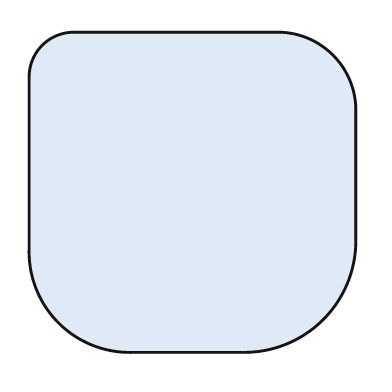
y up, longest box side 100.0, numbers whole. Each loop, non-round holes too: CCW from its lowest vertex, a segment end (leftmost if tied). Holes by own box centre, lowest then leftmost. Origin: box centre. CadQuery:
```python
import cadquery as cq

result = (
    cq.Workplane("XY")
    .moveTo(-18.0, -49.0)
    .lineTo(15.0, -49.0)
    .threePointArc((40.0, -39.0), (50.0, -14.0))
    .lineTo(50.0, 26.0)
    .threePointArc((43.0, 42.0), (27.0, 49.0))
    .lineTo(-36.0, 49.0)
    .threePointArc((-46.0, 45.0), (-50.0, 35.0))
    .lineTo(-50.0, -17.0)
    .threePointArc((-41.0, -40.0), (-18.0, -49.0))
    .close()
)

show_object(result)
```